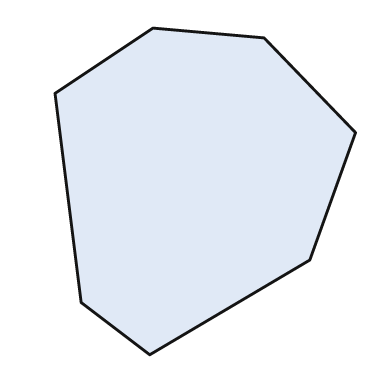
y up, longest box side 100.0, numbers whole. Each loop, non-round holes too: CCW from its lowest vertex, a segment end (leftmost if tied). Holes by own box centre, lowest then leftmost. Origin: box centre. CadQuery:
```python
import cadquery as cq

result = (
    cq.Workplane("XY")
    .moveTo(-17.0, -50.0)
    .lineTo(32.0, -21.0)
    .lineTo(46.0, 18.0)
    .lineTo(18.0, 47.0)
    .lineTo(-16.0, 50.0)
    .lineTo(-46.0, 30.0)
    .lineTo(-38.0, -34.0)
    .close()
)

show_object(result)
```